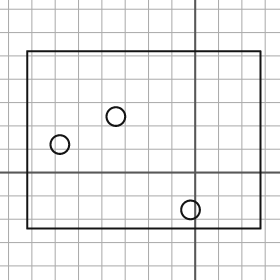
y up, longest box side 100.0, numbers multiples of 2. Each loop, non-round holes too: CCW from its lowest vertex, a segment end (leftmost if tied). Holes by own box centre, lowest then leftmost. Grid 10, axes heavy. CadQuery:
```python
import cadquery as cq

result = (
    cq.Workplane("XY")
    .moveTo(-72.0, -24.0)
    .lineTo(28.0, -24.0)
    .lineTo(28.0, 52.0)
    .lineTo(-72.0, 52.0)
    .close()
    .moveTo(-2.0, -16.0)
    .circle(4.0)
    .moveTo(-58.0, 12.0)
    .circle(4.0)
    .moveTo(-34.0, 24.0)
    .circle(4.0)
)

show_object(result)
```